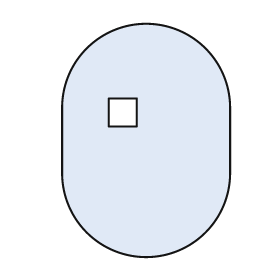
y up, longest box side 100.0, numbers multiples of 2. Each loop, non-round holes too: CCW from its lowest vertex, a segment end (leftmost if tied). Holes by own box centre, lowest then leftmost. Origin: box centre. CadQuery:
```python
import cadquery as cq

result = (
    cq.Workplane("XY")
    .moveTo(-36.0, -14.0)
    .threePointArc((0.0, -50.0), (36.0, -14.0))
    .lineTo(36.0, 14.0)
    .threePointArc((0.0, 50.0), (-36.0, 14.0))
    .close()
    .moveTo(-16.0, 6.0)
    .lineTo(-4.0, 6.0)
    .lineTo(-4.0, 18.0)
    .lineTo(-16.0, 18.0)
    .close()
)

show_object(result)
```